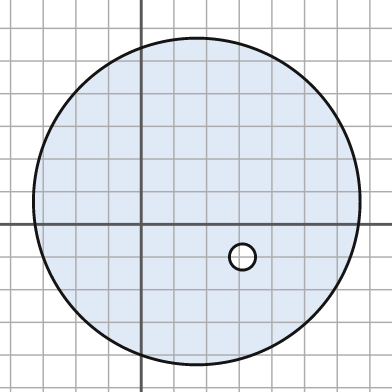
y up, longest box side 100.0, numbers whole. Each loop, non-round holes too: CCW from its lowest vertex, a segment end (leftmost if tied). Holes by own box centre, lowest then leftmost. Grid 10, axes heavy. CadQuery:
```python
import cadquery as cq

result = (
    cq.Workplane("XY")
    .moveTo(17.0, 7.0)
    .circle(50.0)
    .moveTo(31.0, -10.0)
    .circle(4.0)
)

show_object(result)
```